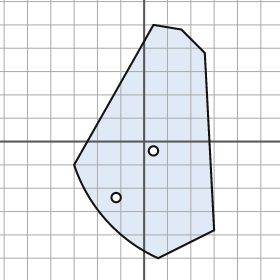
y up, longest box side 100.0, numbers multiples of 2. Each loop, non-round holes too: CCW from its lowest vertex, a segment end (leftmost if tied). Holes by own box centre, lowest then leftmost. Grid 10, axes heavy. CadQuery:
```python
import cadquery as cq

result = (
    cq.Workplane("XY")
    .moveTo(6.0, -50.0)
    .lineTo(30.0, -38.0)
    .lineTo(26.0, 38.0)
    .lineTo(16.0, 48.0)
    .lineTo(4.0, 50.0)
    .lineTo(-30.0, -10.0)
    .threePointArc((-16.0, -34.0), (6.0, -50.0))
    .close()
    .moveTo(-12.0, -24.0)
    .circle(2.0)
    .moveTo(4.0, -4.0)
    .circle(2.0)
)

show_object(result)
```